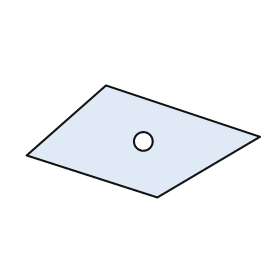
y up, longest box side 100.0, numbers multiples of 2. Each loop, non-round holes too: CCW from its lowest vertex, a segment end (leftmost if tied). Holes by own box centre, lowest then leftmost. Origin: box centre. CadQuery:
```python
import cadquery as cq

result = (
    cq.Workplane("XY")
    .moveTo(6.0, -24.0)
    .lineTo(50.0, 2.0)
    .lineTo(-16.0, 24.0)
    .lineTo(-50.0, -6.0)
    .close()
    .moveTo(0.0, 0.0)
    .circle(4.0)
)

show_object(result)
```